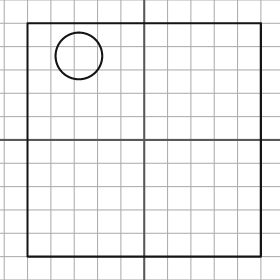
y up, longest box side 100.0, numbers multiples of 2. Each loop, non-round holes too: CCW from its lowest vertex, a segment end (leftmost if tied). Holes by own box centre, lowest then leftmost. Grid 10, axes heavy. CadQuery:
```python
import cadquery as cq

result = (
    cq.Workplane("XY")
    .moveTo(-50.0, -50.0)
    .lineTo(50.0, -50.0)
    .lineTo(50.0, 50.0)
    .lineTo(-50.0, 50.0)
    .close()
    .moveTo(-28.0, 36.0)
    .circle(10.0)
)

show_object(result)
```